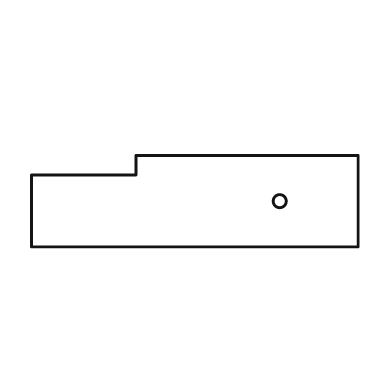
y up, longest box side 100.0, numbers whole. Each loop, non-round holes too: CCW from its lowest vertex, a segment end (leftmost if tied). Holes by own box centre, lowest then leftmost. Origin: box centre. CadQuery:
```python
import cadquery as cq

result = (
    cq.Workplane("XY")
    .moveTo(-50.0, -14.0)
    .lineTo(50.0, -14.0)
    .lineTo(50.0, 14.0)
    .lineTo(-18.0, 14.0)
    .lineTo(-18.0, 8.0)
    .lineTo(-50.0, 8.0)
    .close()
    .moveTo(26.0, 0.0)
    .circle(2.0)
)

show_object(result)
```